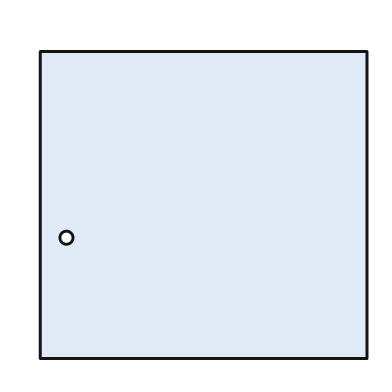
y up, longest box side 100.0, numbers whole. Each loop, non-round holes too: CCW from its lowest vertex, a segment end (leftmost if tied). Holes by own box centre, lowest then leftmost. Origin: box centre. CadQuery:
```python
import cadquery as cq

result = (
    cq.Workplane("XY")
    .moveTo(-50.0, -47.0)
    .lineTo(50.0, -47.0)
    .lineTo(50.0, 47.0)
    .lineTo(-50.0, 47.0)
    .close()
    .moveTo(-42.0, -10.0)
    .circle(2.0)
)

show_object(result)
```